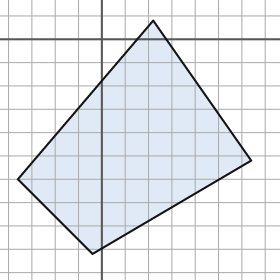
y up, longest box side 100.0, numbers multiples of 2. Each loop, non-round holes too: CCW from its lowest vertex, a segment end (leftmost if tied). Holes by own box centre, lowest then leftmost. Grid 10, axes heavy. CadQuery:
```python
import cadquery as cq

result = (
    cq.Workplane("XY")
    .moveTo(-4.0, -92.0)
    .lineTo(64.0, -52.0)
    .lineTo(22.0, 8.0)
    .lineTo(-36.0, -60.0)
    .close()
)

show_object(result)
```